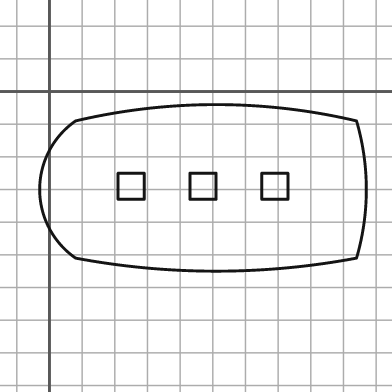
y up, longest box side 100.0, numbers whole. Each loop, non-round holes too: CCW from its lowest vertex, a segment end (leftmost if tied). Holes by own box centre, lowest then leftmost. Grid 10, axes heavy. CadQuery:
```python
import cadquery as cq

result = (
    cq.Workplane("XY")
    .moveTo(8.0, -51.0)
    .threePointArc((51.0, -55.0), (94.0, -51.0))
    .threePointArc((97.0, -30.0), (94.0, -9.0))
    .threePointArc((51.0, -4.0), (8.0, -9.0))
    .threePointArc((-3.0, -30.0), (8.0, -51.0))
    .close()
    .moveTo(21.0, -33.0)
    .lineTo(29.0, -33.0)
    .lineTo(29.0, -25.0)
    .lineTo(21.0, -25.0)
    .close()
    .moveTo(43.0, -33.0)
    .lineTo(51.0, -33.0)
    .lineTo(51.0, -25.0)
    .lineTo(43.0, -25.0)
    .close()
    .moveTo(65.0, -33.0)
    .lineTo(73.0, -33.0)
    .lineTo(73.0, -25.0)
    .lineTo(65.0, -25.0)
    .close()
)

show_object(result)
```